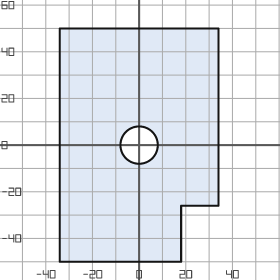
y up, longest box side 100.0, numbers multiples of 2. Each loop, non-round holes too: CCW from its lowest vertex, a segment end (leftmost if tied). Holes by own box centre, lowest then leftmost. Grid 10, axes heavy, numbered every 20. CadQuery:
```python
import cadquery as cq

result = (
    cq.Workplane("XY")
    .moveTo(-34.0, -50.0)
    .lineTo(18.0, -50.0)
    .lineTo(18.0, -26.0)
    .lineTo(34.0, -26.0)
    .lineTo(34.0, 50.0)
    .lineTo(-34.0, 50.0)
    .close()
    .moveTo(0.0, 0.0)
    .circle(8.0)
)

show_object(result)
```